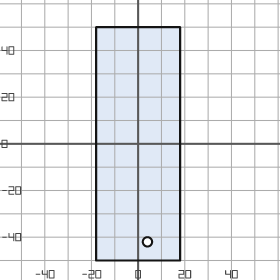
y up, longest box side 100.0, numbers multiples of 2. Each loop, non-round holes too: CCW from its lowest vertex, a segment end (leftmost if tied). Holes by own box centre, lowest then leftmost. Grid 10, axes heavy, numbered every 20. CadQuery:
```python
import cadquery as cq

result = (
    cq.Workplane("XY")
    .moveTo(-18.0, -50.0)
    .lineTo(18.0, -50.0)
    .lineTo(18.0, 50.0)
    .lineTo(-18.0, 50.0)
    .close()
    .moveTo(4.0, -42.0)
    .circle(2.0)
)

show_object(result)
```